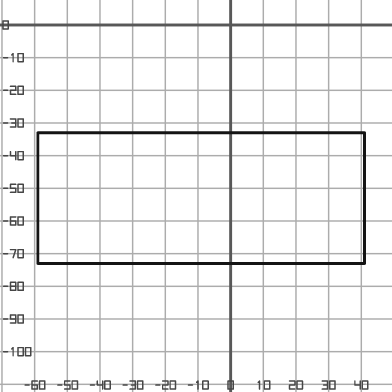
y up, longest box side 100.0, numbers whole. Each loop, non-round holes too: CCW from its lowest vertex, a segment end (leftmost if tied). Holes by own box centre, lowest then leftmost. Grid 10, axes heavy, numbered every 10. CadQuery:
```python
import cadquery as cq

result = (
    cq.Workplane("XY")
    .moveTo(-59.0, -73.0)
    .lineTo(41.0, -73.0)
    .lineTo(41.0, -33.0)
    .lineTo(-59.0, -33.0)
    .close()
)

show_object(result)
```